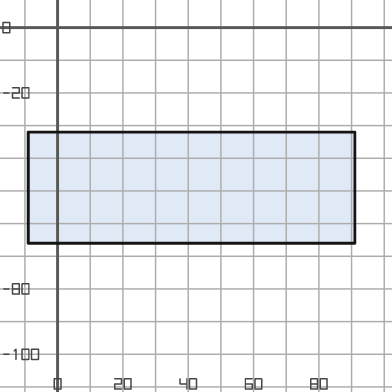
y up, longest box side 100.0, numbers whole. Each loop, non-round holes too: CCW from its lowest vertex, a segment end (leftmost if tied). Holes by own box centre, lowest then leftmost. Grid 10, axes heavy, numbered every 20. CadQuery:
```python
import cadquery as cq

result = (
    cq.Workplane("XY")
    .moveTo(-9.0, -66.0)
    .lineTo(91.0, -66.0)
    .lineTo(91.0, -32.0)
    .lineTo(-9.0, -32.0)
    .close()
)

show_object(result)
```